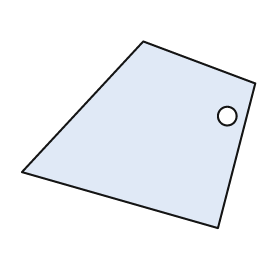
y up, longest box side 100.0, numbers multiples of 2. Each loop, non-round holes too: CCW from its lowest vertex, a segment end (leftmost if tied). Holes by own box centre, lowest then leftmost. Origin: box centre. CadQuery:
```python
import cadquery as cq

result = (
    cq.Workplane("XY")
    .moveTo(34.0, -40.0)
    .lineTo(50.0, 22.0)
    .lineTo(2.0, 40.0)
    .lineTo(-50.0, -16.0)
    .close()
    .moveTo(38.0, 8.0)
    .circle(4.0)
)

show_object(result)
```